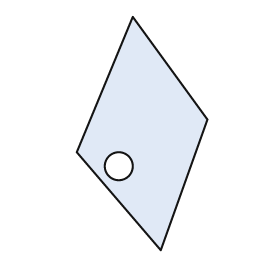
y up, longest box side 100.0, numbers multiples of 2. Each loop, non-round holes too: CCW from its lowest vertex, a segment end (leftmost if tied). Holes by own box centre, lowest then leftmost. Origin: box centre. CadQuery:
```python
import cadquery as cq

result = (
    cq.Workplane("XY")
    .moveTo(8.0, -50.0)
    .lineTo(28.0, 6.0)
    .lineTo(-4.0, 50.0)
    .lineTo(-28.0, -8.0)
    .close()
    .moveTo(-10.0, -14.0)
    .circle(6.0)
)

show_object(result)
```